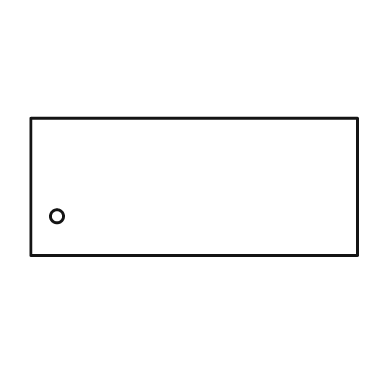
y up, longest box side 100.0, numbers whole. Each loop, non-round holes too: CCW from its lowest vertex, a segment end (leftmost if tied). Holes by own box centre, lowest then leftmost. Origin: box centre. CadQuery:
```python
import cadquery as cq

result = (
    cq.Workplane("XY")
    .moveTo(-50.0, -21.0)
    .lineTo(50.0, -21.0)
    .lineTo(50.0, 21.0)
    .lineTo(-50.0, 21.0)
    .close()
    .moveTo(-42.0, -9.0)
    .circle(2.0)
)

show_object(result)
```